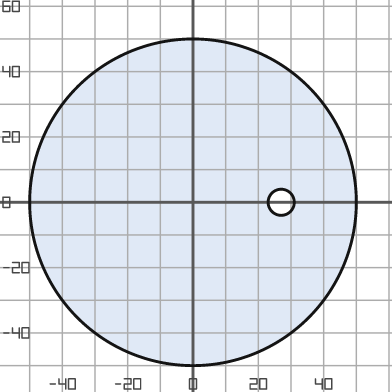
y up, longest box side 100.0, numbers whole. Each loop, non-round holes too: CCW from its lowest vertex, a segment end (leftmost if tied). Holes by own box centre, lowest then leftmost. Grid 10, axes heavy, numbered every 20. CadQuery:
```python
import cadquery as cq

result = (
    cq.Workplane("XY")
    .moveTo(0.0, 0.0)
    .circle(50.0)
    .moveTo(27.0, 0.0)
    .circle(4.0)
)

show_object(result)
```